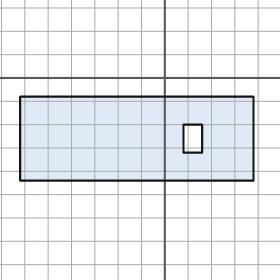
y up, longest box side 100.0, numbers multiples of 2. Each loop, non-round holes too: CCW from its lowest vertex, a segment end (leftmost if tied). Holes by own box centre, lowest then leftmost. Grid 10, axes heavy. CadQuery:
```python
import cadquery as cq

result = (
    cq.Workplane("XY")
    .moveTo(-62.0, -44.0)
    .lineTo(38.0, -44.0)
    .lineTo(38.0, -8.0)
    .lineTo(-62.0, -8.0)
    .close()
    .moveTo(8.0, -32.0)
    .lineTo(16.0, -32.0)
    .lineTo(16.0, -20.0)
    .lineTo(8.0, -20.0)
    .close()
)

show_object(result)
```